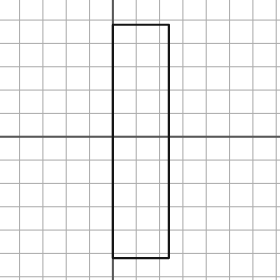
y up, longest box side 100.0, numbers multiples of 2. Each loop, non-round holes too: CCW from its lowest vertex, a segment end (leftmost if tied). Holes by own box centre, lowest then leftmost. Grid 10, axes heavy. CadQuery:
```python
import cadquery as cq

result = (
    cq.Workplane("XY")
    .moveTo(0.0, -52.0)
    .lineTo(24.0, -52.0)
    .lineTo(24.0, 48.0)
    .lineTo(0.0, 48.0)
    .close()
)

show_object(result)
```